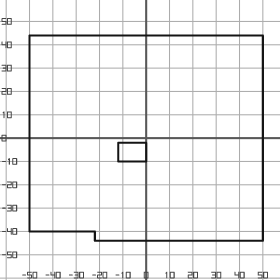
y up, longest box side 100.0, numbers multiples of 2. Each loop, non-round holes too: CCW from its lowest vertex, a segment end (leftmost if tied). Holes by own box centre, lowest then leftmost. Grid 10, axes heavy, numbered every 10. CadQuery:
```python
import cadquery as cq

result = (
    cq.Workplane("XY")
    .moveTo(-22.0, -44.0)
    .lineTo(50.0, -44.0)
    .lineTo(50.0, 44.0)
    .lineTo(-50.0, 44.0)
    .lineTo(-50.0, -40.0)
    .lineTo(-22.0, -40.0)
    .close()
    .moveTo(-12.0, -10.0)
    .lineTo(0.0, -10.0)
    .lineTo(0.0, -2.0)
    .lineTo(-12.0, -2.0)
    .close()
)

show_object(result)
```